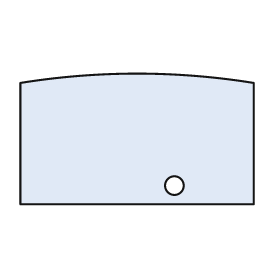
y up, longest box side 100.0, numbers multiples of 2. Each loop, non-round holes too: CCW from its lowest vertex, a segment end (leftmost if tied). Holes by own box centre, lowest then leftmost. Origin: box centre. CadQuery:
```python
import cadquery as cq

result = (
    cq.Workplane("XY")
    .moveTo(-50.0, -28.0)
    .lineTo(50.0, -28.0)
    .lineTo(50.0, 24.0)
    .threePointArc((0.0, 28.0), (-50.0, 24.0))
    .close()
    .moveTo(16.0, -20.0)
    .circle(4.0)
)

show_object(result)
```